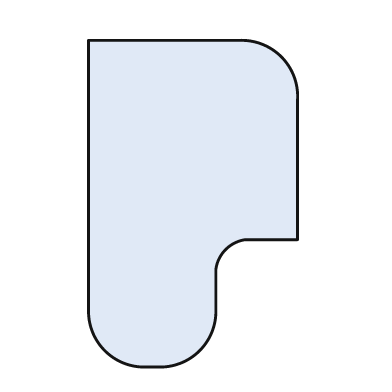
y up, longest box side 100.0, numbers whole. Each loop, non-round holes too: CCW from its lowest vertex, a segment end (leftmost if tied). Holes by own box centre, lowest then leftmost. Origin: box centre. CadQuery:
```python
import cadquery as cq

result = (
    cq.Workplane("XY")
    .moveTo(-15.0, -50.0)
    .lineTo(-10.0, -50.0)
    .threePointArc((2.0, -45.0), (7.0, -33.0))
    .lineTo(7.0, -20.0)
    .threePointArc((10.0, -14.0), (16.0, -11.0))
    .lineTo(32.0, -11.0)
    .lineTo(32.0, 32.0)
    .threePointArc((27.0, 45.0), (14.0, 50.0))
    .lineTo(-32.0, 50.0)
    .lineTo(-32.0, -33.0)
    .threePointArc((-27.0, -45.0), (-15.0, -50.0))
    .close()
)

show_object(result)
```